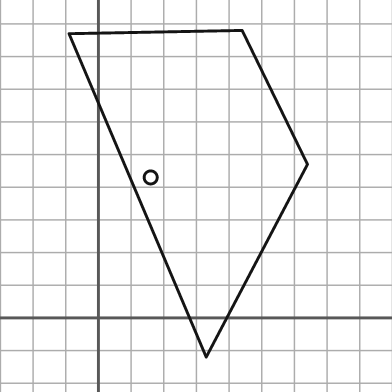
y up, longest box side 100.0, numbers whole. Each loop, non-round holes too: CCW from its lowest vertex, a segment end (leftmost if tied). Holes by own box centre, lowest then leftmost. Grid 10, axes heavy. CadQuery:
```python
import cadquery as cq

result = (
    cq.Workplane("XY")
    .moveTo(33.0, -12.0)
    .lineTo(64.0, 47.0)
    .lineTo(44.0, 88.0)
    .lineTo(-9.0, 87.0)
    .close()
    .moveTo(16.0, 43.0)
    .circle(2.0)
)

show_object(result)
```